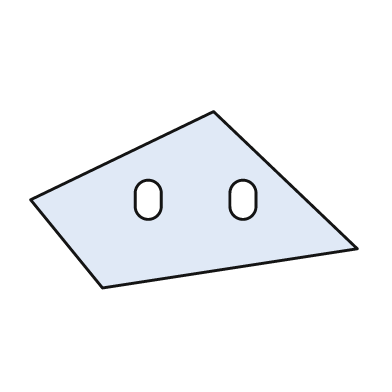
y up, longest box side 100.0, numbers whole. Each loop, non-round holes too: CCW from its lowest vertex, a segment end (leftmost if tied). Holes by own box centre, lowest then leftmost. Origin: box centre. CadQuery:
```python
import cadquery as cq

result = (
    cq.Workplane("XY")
    .moveTo(-28.0, -27.0)
    .lineTo(50.0, -15.0)
    .lineTo(6.0, 27.0)
    .lineTo(-50.0, 0.0)
    .close()
    .moveTo(-18.0, -2.0)
    .threePointArc((-14.0, -6.0), (-10.0, -2.0))
    .lineTo(-10.0, 2.0)
    .threePointArc((-14.0, 6.0), (-18.0, 2.0))
    .close()
    .moveTo(11.0, -2.0)
    .threePointArc((15.0, -6.0), (19.0, -2.0))
    .lineTo(19.0, 2.0)
    .threePointArc((15.0, 6.0), (11.0, 2.0))
    .close()
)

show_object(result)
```